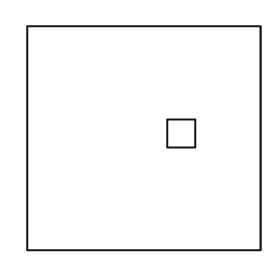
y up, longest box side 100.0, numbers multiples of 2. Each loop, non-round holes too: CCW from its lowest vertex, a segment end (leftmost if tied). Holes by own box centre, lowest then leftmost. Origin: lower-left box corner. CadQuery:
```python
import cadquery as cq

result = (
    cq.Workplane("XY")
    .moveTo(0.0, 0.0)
    .lineTo(100.0, 0.0)
    .lineTo(100.0, 96.0)
    .lineTo(0.0, 96.0)
    .close()
    .moveTo(60.0, 44.0)
    .lineTo(72.0, 44.0)
    .lineTo(72.0, 56.0)
    .lineTo(60.0, 56.0)
    .close()
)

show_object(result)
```